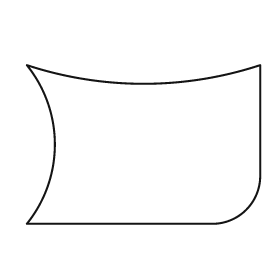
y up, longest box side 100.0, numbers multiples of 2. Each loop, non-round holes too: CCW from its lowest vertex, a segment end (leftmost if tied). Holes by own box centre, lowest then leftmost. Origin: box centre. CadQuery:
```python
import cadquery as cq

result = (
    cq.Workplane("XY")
    .moveTo(-50.0, -34.0)
    .lineTo(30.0, -34.0)
    .threePointArc((44.0, -28.0), (50.0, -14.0))
    .lineTo(50.0, 34.0)
    .threePointArc((0.0, 26.0), (-50.0, 34.0))
    .threePointArc((-38.0, 0.0), (-50.0, -34.0))
    .close()
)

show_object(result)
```